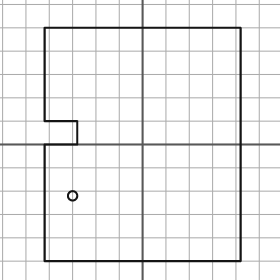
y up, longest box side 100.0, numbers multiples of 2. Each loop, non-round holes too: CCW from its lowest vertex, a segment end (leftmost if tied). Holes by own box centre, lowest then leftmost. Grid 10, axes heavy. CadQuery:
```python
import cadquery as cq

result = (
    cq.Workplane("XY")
    .moveTo(-42.0, -50.0)
    .lineTo(42.0, -50.0)
    .lineTo(42.0, 50.0)
    .lineTo(-42.0, 50.0)
    .lineTo(-42.0, 10.0)
    .lineTo(-28.0, 10.0)
    .lineTo(-28.0, 0.0)
    .lineTo(-42.0, 0.0)
    .close()
    .moveTo(-30.0, -22.0)
    .circle(2.0)
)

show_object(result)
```